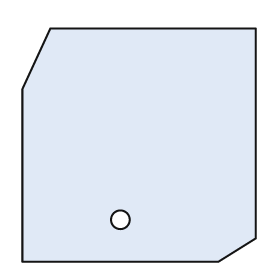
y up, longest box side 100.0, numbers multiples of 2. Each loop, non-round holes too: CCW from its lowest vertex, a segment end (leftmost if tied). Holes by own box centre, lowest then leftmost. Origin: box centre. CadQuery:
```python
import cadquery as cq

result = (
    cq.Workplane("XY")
    .moveTo(-50.0, -50.0)
    .lineTo(34.0, -50.0)
    .lineTo(50.0, -40.0)
    .lineTo(50.0, 50.0)
    .lineTo(-38.0, 50.0)
    .lineTo(-50.0, 24.0)
    .close()
    .moveTo(-8.0, -32.0)
    .circle(4.0)
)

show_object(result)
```